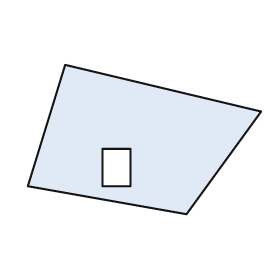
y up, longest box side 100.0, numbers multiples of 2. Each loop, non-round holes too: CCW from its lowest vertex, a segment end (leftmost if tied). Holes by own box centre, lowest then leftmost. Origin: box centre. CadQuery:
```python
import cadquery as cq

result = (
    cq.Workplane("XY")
    .moveTo(18.0, -32.0)
    .lineTo(50.0, 12.0)
    .lineTo(-34.0, 32.0)
    .lineTo(-50.0, -20.0)
    .close()
    .moveTo(-18.0, -20.0)
    .lineTo(-6.0, -20.0)
    .lineTo(-6.0, -4.0)
    .lineTo(-18.0, -4.0)
    .close()
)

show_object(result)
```